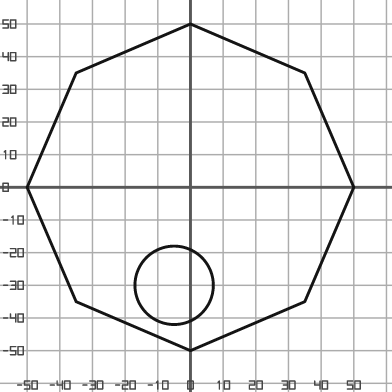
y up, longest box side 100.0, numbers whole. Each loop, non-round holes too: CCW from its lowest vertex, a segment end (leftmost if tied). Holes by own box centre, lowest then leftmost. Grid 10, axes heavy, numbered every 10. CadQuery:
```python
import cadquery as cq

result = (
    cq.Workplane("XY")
    .moveTo(0.0, -50.0)
    .lineTo(35.0, -35.0)
    .lineTo(50.0, 0.0)
    .lineTo(35.0, 35.0)
    .lineTo(0.0, 50.0)
    .lineTo(-35.0, 35.0)
    .lineTo(-50.0, 0.0)
    .lineTo(-35.0, -35.0)
    .close()
    .moveTo(-5.0, -30.0)
    .circle(12.0)
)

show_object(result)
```